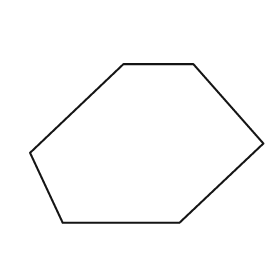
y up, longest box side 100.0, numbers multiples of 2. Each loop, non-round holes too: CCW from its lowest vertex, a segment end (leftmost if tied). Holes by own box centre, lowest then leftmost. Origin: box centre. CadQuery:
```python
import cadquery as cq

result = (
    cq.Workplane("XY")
    .moveTo(-36.0, -34.0)
    .lineTo(14.0, -34.0)
    .lineTo(50.0, 0.0)
    .lineTo(20.0, 34.0)
    .lineTo(-10.0, 34.0)
    .lineTo(-50.0, -4.0)
    .close()
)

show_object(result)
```